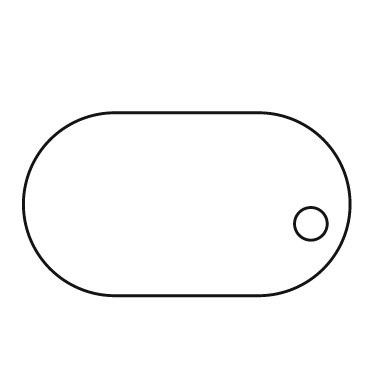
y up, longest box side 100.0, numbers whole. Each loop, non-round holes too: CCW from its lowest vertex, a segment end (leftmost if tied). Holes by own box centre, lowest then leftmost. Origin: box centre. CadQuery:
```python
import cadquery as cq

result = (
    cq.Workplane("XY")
    .moveTo(-22.0, -28.0)
    .lineTo(22.0, -28.0)
    .threePointArc((50.0, 0.0), (22.0, 28.0))
    .lineTo(-22.0, 28.0)
    .threePointArc((-50.0, 0.0), (-22.0, -28.0))
    .close()
    .moveTo(38.0, -6.0)
    .circle(5.0)
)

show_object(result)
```